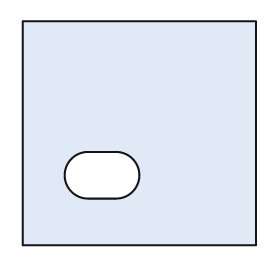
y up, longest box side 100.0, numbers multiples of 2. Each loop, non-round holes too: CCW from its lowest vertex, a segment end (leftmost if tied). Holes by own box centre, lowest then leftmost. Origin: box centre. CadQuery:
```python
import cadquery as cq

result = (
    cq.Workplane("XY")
    .moveTo(-50.0, -48.0)
    .lineTo(50.0, -48.0)
    .lineTo(50.0, 48.0)
    .lineTo(-50.0, 48.0)
    .close()
    .moveTo(-22.0, -28.0)
    .lineTo(-10.0, -28.0)
    .threePointArc((0.0, -18.0), (-10.0, -8.0))
    .lineTo(-22.0, -8.0)
    .threePointArc((-32.0, -18.0), (-22.0, -28.0))
    .close()
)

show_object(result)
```